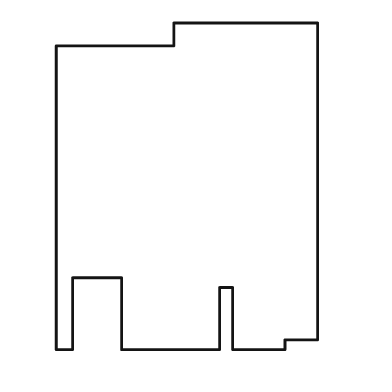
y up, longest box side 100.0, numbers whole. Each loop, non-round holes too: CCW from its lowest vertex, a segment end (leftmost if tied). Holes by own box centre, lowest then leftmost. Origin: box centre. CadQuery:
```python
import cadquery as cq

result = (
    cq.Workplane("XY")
    .moveTo(-40.0, -50.0)
    .lineTo(-35.0, -50.0)
    .lineTo(-35.0, -28.0)
    .lineTo(-20.0, -28.0)
    .lineTo(-20.0, -50.0)
    .lineTo(10.0, -50.0)
    .lineTo(10.0, -31.0)
    .lineTo(14.0, -31.0)
    .lineTo(14.0, -50.0)
    .lineTo(30.0, -50.0)
    .lineTo(30.0, -47.0)
    .lineTo(40.0, -47.0)
    .lineTo(40.0, 50.0)
    .lineTo(-4.0, 50.0)
    .lineTo(-4.0, 43.0)
    .lineTo(-40.0, 43.0)
    .close()
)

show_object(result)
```